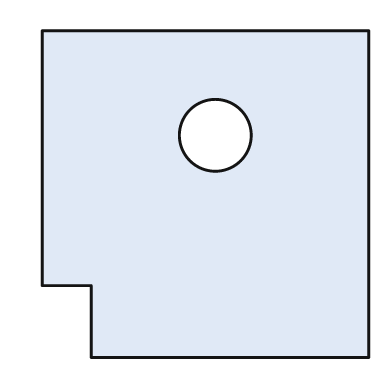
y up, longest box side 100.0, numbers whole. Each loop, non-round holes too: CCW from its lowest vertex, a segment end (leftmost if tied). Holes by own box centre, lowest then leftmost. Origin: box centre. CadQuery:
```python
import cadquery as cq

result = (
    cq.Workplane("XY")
    .moveTo(-35.0, -50.0)
    .lineTo(50.0, -50.0)
    .lineTo(50.0, 50.0)
    .lineTo(-50.0, 50.0)
    .lineTo(-50.0, -28.0)
    .lineTo(-35.0, -28.0)
    .close()
    .moveTo(3.0, 18.0)
    .circle(11.0)
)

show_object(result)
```